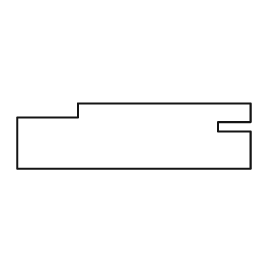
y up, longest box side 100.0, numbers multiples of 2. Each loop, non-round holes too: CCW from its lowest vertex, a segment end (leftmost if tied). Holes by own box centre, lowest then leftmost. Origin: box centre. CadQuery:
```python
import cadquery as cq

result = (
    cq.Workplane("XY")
    .moveTo(-50.0, -14.0)
    .lineTo(50.0, -14.0)
    .lineTo(50.0, 2.0)
    .lineTo(36.0, 2.0)
    .lineTo(36.0, 6.0)
    .lineTo(50.0, 6.0)
    .lineTo(50.0, 14.0)
    .lineTo(-24.0, 14.0)
    .lineTo(-24.0, 8.0)
    .lineTo(-50.0, 8.0)
    .close()
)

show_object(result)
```